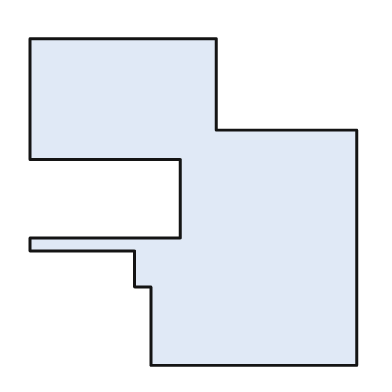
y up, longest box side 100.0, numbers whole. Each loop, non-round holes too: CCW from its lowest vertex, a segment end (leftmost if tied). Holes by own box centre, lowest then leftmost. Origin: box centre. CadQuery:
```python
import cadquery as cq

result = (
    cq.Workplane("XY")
    .moveTo(-13.0, -50.0)
    .lineTo(50.0, -50.0)
    .lineTo(50.0, 22.0)
    .lineTo(7.0, 22.0)
    .lineTo(7.0, 50.0)
    .lineTo(-50.0, 50.0)
    .lineTo(-50.0, 13.0)
    .lineTo(-4.0, 13.0)
    .lineTo(-4.0, -11.0)
    .lineTo(-50.0, -11.0)
    .lineTo(-50.0, -15.0)
    .lineTo(-18.0, -15.0)
    .lineTo(-18.0, -26.0)
    .lineTo(-13.0, -26.0)
    .close()
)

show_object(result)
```